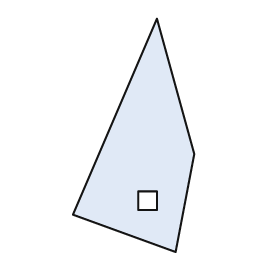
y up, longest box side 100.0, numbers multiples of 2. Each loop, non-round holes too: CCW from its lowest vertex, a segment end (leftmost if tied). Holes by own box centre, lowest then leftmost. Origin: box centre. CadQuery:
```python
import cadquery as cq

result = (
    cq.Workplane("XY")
    .moveTo(18.0, -50.0)
    .lineTo(26.0, -8.0)
    .lineTo(10.0, 50.0)
    .lineTo(-26.0, -34.0)
    .close()
    .moveTo(2.0, -32.0)
    .lineTo(10.0, -32.0)
    .lineTo(10.0, -24.0)
    .lineTo(2.0, -24.0)
    .close()
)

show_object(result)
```